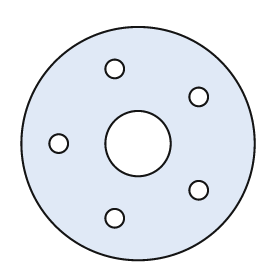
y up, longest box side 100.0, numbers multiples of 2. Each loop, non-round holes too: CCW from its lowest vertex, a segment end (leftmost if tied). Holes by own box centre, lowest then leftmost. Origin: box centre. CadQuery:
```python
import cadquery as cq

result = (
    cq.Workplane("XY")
    .moveTo(0.0, 0.0)
    .circle(50.0)
    .moveTo(-10.0, -32.0)
    .circle(4.0)
    .moveTo(26.0, -20.0)
    .circle(4.0)
    .moveTo(-34.0, 0.0)
    .circle(4.0)
    .moveTo(0.0, 0.0)
    .circle(14.0)
    .moveTo(26.0, 20.0)
    .circle(4.0)
    .moveTo(-10.0, 32.0)
    .circle(4.0)
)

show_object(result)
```